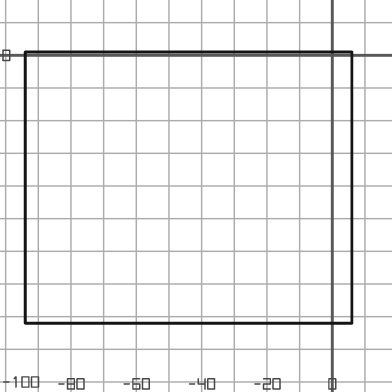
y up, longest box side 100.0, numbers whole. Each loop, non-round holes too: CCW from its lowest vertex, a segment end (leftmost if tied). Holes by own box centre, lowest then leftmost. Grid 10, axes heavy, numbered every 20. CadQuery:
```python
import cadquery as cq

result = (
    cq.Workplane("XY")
    .moveTo(-94.0, -82.0)
    .lineTo(6.0, -82.0)
    .lineTo(6.0, 1.0)
    .lineTo(-94.0, 1.0)
    .close()
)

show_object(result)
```